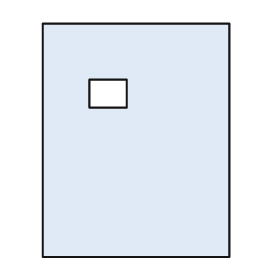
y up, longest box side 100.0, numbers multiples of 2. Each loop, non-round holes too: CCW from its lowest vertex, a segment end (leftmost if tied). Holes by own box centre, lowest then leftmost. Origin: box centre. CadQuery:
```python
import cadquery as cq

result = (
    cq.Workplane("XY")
    .moveTo(-40.0, -50.0)
    .lineTo(40.0, -50.0)
    .lineTo(40.0, 50.0)
    .lineTo(-40.0, 50.0)
    .close()
    .moveTo(-20.0, 14.0)
    .lineTo(-4.0, 14.0)
    .lineTo(-4.0, 26.0)
    .lineTo(-20.0, 26.0)
    .close()
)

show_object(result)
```